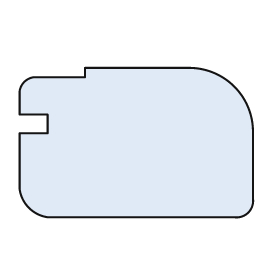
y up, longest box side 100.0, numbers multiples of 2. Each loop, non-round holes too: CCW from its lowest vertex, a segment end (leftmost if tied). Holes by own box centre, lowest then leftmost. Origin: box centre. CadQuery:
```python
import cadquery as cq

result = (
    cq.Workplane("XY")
    .moveTo(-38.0, -32.0)
    .lineTo(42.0, -32.0)
    .threePointArc((48.0, -30.0), (50.0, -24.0))
    .lineTo(50.0, 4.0)
    .threePointArc((42.0, 24.0), (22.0, 32.0))
    .lineTo(-22.0, 32.0)
    .lineTo(-22.0, 28.0)
    .lineTo(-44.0, 28.0)
    .threePointArc((-48.0, 26.0), (-50.0, 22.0))
    .lineTo(-50.0, 12.0)
    .lineTo(-38.0, 12.0)
    .lineTo(-38.0, 4.0)
    .lineTo(-50.0, 4.0)
    .lineTo(-50.0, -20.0)
    .threePointArc((-46.0, -28.0), (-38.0, -32.0))
    .close()
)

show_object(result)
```